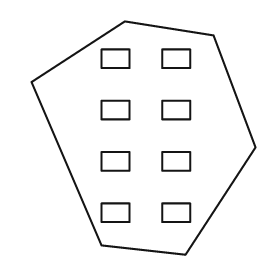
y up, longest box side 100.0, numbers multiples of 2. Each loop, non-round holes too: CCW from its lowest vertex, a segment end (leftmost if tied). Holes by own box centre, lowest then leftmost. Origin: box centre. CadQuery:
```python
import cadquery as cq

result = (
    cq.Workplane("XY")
    .moveTo(18.0, -50.0)
    .lineTo(48.0, -4.0)
    .lineTo(30.0, 44.0)
    .lineTo(-8.0, 50.0)
    .lineTo(-48.0, 24.0)
    .lineTo(-18.0, -46.0)
    .close()
    .moveTo(-18.0, -36.0)
    .lineTo(-6.0, -36.0)
    .lineTo(-6.0, -28.0)
    .lineTo(-18.0, -28.0)
    .close()
    .moveTo(8.0, -36.0)
    .lineTo(20.0, -36.0)
    .lineTo(20.0, -28.0)
    .lineTo(8.0, -28.0)
    .close()
    .moveTo(-18.0, -14.0)
    .lineTo(-6.0, -14.0)
    .lineTo(-6.0, -6.0)
    .lineTo(-18.0, -6.0)
    .close()
    .moveTo(8.0, -14.0)
    .lineTo(20.0, -14.0)
    .lineTo(20.0, -6.0)
    .lineTo(8.0, -6.0)
    .close()
    .moveTo(-18.0, 8.0)
    .lineTo(-6.0, 8.0)
    .lineTo(-6.0, 16.0)
    .lineTo(-18.0, 16.0)
    .close()
    .moveTo(8.0, 8.0)
    .lineTo(20.0, 8.0)
    .lineTo(20.0, 16.0)
    .lineTo(8.0, 16.0)
    .close()
    .moveTo(-18.0, 30.0)
    .lineTo(-6.0, 30.0)
    .lineTo(-6.0, 38.0)
    .lineTo(-18.0, 38.0)
    .close()
    .moveTo(8.0, 30.0)
    .lineTo(20.0, 30.0)
    .lineTo(20.0, 38.0)
    .lineTo(8.0, 38.0)
    .close()
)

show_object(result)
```